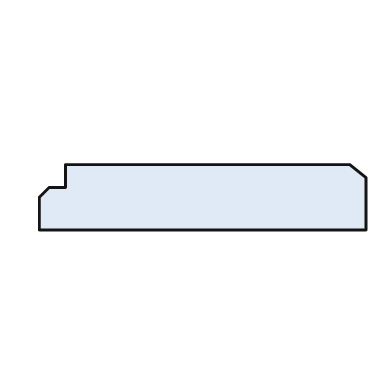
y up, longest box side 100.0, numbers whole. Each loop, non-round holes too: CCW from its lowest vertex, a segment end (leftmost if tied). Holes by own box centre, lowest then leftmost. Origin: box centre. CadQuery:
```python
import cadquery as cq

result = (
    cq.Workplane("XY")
    .moveTo(-50.0, -10.0)
    .lineTo(50.0, -10.0)
    .lineTo(50.0, 6.0)
    .lineTo(45.0, 10.0)
    .lineTo(-42.0, 10.0)
    .lineTo(-42.0, 3.0)
    .lineTo(-47.0, 3.0)
    .lineTo(-50.0, 0.0)
    .close()
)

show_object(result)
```